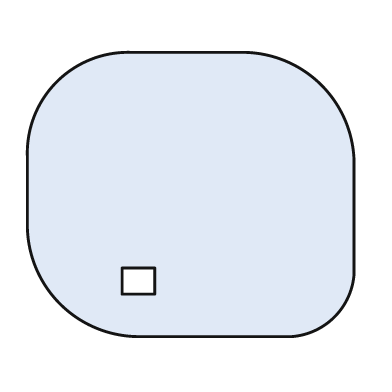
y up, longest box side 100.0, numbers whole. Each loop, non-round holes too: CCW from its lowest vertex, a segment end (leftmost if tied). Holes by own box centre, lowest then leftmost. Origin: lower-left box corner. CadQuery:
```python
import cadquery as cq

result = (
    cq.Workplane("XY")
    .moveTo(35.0, 0.0)
    .lineTo(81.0, 0.0)
    .threePointArc((94.0, 6.0), (100.0, 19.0))
    .lineTo(100.0, 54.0)
    .threePointArc((90.0, 77.0), (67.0, 87.0))
    .lineTo(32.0, 87.0)
    .threePointArc((9.0, 78.0), (0.0, 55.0))
    .lineTo(0.0, 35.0)
    .threePointArc((10.0, 10.0), (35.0, 0.0))
    .close()
    .moveTo(29.0, 13.0)
    .lineTo(39.0, 13.0)
    .lineTo(39.0, 21.0)
    .lineTo(29.0, 21.0)
    .close()
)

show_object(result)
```